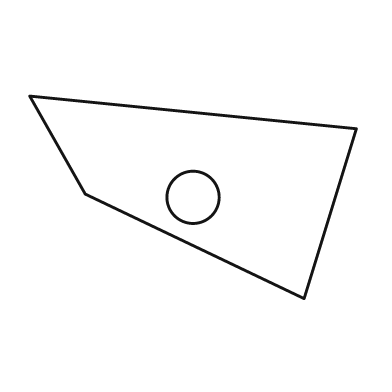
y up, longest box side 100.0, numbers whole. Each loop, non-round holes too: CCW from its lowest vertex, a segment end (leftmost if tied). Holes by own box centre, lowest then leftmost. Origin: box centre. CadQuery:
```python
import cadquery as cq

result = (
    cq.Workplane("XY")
    .moveTo(34.0, -31.0)
    .lineTo(50.0, 21.0)
    .lineTo(-50.0, 31.0)
    .lineTo(-33.0, 1.0)
    .close()
    .moveTo(0.0, 0.0)
    .circle(8.0)
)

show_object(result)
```